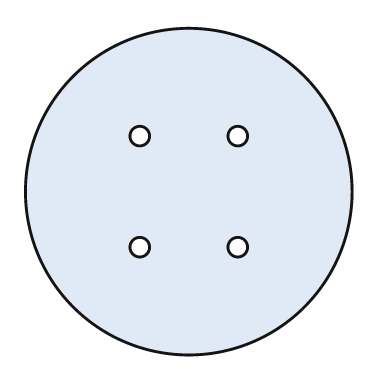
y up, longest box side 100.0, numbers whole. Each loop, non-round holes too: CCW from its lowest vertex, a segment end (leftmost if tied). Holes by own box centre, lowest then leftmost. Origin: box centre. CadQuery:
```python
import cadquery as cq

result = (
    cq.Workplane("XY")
    .moveTo(0.0, 0.0)
    .circle(50.0)
    .moveTo(-15.0, -17.0)
    .circle(3.0)
    .moveTo(15.0, -17.0)
    .circle(3.0)
    .moveTo(-15.0, 17.0)
    .circle(3.0)
    .moveTo(15.0, 17.0)
    .circle(3.0)
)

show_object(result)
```